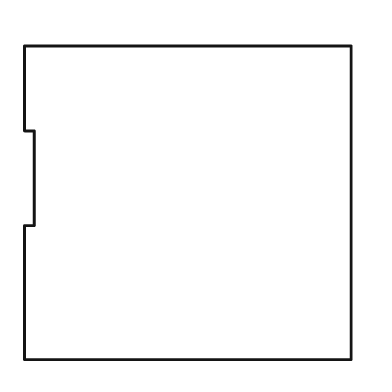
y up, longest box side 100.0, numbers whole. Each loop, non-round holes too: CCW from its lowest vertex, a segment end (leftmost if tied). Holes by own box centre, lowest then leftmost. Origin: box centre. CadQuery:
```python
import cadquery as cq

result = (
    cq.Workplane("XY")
    .moveTo(-50.0, -48.0)
    .lineTo(50.0, -48.0)
    .lineTo(50.0, 48.0)
    .lineTo(-50.0, 48.0)
    .lineTo(-50.0, 22.0)
    .lineTo(-47.0, 22.0)
    .lineTo(-47.0, -7.0)
    .lineTo(-50.0, -7.0)
    .close()
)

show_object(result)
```